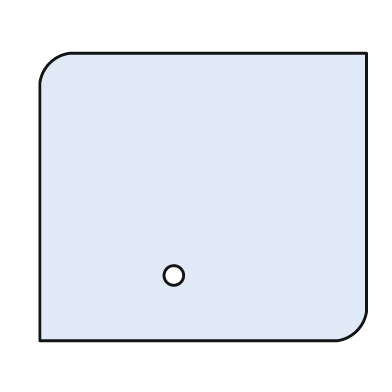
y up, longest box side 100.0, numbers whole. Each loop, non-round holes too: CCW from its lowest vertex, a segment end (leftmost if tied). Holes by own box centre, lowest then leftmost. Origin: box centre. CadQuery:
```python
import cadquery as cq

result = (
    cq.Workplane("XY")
    .moveTo(-50.0, -44.0)
    .lineTo(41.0, -44.0)
    .threePointArc((47.0, -41.0), (50.0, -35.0))
    .lineTo(50.0, 44.0)
    .lineTo(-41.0, 44.0)
    .threePointArc((-47.0, 41.0), (-50.0, 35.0))
    .close()
    .moveTo(-9.0, -24.0)
    .circle(3.0)
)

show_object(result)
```